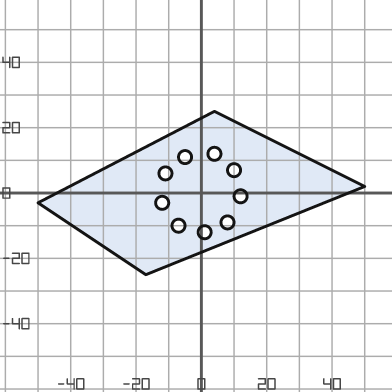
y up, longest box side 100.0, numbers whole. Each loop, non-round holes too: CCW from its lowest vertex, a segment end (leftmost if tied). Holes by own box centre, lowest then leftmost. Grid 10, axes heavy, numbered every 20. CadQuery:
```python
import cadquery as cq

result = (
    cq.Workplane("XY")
    .moveTo(-17.0, -25.0)
    .lineTo(50.0, 2.0)
    .lineTo(4.0, 25.0)
    .lineTo(-50.0, -3.0)
    .close()
    .moveTo(1.0, -12.0)
    .circle(2.0)
    .moveTo(-7.0, -10.0)
    .circle(2.0)
    .moveTo(8.0, -9.0)
    .circle(2.0)
    .moveTo(-12.0, -3.0)
    .circle(2.0)
    .moveTo(12.0, -1.0)
    .circle(2.0)
    .moveTo(-11.0, 6.0)
    .circle(2.0)
    .moveTo(10.0, 7.0)
    .circle(2.0)
    .moveTo(-5.0, 11.0)
    .circle(2.0)
    .moveTo(4.0, 12.0)
    .circle(2.0)
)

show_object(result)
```